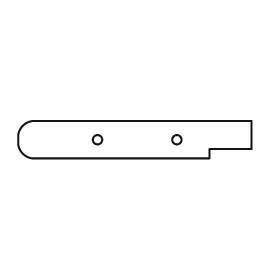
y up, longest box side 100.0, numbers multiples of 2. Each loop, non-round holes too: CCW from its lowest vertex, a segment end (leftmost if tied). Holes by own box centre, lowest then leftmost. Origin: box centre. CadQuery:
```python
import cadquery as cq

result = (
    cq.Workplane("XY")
    .moveTo(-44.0, -8.0)
    .lineTo(32.0, -8.0)
    .lineTo(32.0, -4.0)
    .lineTo(50.0, -4.0)
    .lineTo(50.0, 8.0)
    .lineTo(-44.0, 8.0)
    .threePointArc((-48.0, 6.0), (-50.0, 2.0))
    .lineTo(-50.0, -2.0)
    .threePointArc((-48.0, -6.0), (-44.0, -8.0))
    .close()
    .moveTo(-16.0, 0.0)
    .circle(2.0)
    .moveTo(18.0, 0.0)
    .circle(2.0)
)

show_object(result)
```